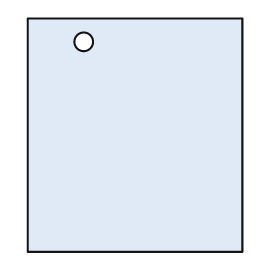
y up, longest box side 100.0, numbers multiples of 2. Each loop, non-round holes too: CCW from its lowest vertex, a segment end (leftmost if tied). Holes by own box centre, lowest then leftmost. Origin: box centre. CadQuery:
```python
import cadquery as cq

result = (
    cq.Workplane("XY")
    .moveTo(-46.0, -50.0)
    .lineTo(46.0, -50.0)
    .lineTo(46.0, 50.0)
    .lineTo(-46.0, 50.0)
    .close()
    .moveTo(-22.0, 40.0)
    .circle(4.0)
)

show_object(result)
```